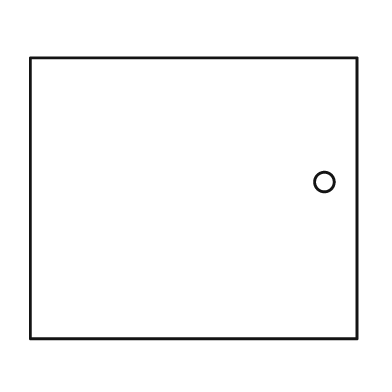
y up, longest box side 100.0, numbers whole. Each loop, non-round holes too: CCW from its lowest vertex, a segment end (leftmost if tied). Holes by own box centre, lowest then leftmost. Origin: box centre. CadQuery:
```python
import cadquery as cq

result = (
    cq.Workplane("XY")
    .moveTo(-50.0, -43.0)
    .lineTo(50.0, -43.0)
    .lineTo(50.0, 43.0)
    .lineTo(-50.0, 43.0)
    .close()
    .moveTo(40.0, 5.0)
    .circle(3.0)
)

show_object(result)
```